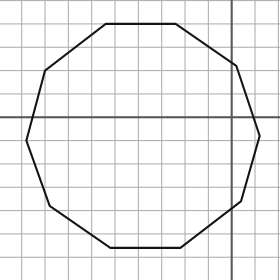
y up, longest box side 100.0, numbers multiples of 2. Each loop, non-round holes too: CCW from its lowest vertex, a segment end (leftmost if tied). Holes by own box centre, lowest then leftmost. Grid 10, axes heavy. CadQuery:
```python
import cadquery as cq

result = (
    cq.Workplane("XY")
    .moveTo(-52.0, -56.0)
    .lineTo(-22.0, -56.0)
    .lineTo(4.0, -36.0)
    .lineTo(12.0, -8.0)
    .lineTo(2.0, 22.0)
    .lineTo(-24.0, 40.0)
    .lineTo(-54.0, 40.0)
    .lineTo(-80.0, 20.0)
    .lineTo(-88.0, -10.0)
    .lineTo(-78.0, -38.0)
    .close()
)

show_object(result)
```